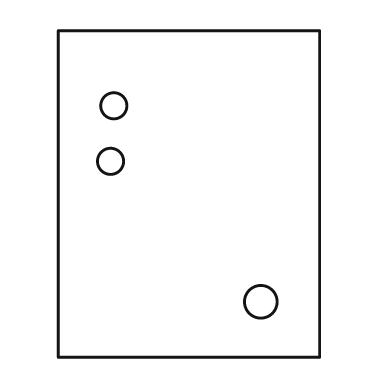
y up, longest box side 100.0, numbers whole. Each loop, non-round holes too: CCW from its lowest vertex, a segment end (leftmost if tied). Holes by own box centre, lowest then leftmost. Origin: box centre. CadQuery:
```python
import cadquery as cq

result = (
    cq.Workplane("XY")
    .moveTo(-40.0, -50.0)
    .lineTo(40.0, -50.0)
    .lineTo(40.0, 50.0)
    .lineTo(-40.0, 50.0)
    .close()
    .moveTo(22.0, -33.0)
    .circle(5.0)
    .moveTo(-24.0, 10.0)
    .circle(4.0)
    .moveTo(-23.0, 27.0)
    .circle(4.0)
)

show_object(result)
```